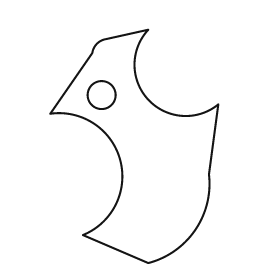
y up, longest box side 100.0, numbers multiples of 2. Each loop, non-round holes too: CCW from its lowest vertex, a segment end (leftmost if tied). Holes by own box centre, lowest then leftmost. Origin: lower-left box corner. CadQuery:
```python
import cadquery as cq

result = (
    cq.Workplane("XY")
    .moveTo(42.0, 0.0)
    .threePointArc((62.0, 14.0), (68.0, 38.0))
    .lineTo(72.0, 68.0)
    .threePointArc((42.0, 70.0), (42.0, 100.0))
    .lineTo(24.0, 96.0)
    .threePointArc((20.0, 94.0), (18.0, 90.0))
    .lineTo(0.0, 64.0)
    .threePointArc((30.0, 44.0), (14.0, 12.0))
    .close()
    .moveTo(22.0, 72.0)
    .circle(6.0)
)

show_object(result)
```